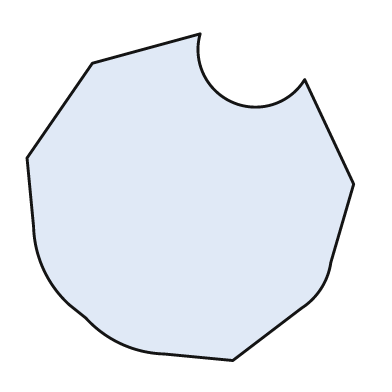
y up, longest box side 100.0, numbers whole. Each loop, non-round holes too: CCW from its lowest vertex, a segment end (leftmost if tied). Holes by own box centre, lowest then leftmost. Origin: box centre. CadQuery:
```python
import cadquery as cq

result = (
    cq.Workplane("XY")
    .moveTo(13.0, -50.0)
    .lineTo(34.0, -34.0)
    .threePointArc((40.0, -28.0), (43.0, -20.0))
    .lineTo(50.0, 4.0)
    .lineTo(35.0, 36.0)
    .threePointArc((13.0, 29.0), (3.0, 50.0))
    .lineTo(-30.0, 41.0)
    .lineTo(-50.0, 12.0)
    .lineTo(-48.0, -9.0)
    .threePointArc((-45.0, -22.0), (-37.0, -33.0))
    .lineTo(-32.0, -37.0)
    .threePointArc((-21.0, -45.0), (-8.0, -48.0))
    .close()
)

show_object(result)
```